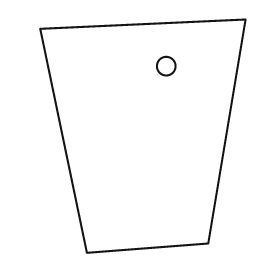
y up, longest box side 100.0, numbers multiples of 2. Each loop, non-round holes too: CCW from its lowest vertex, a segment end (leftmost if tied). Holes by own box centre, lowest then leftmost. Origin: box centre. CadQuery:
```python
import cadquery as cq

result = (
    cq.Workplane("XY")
    .moveTo(-24.0, -50.0)
    .lineTo(28.0, -46.0)
    .lineTo(44.0, 50.0)
    .lineTo(-44.0, 46.0)
    .close()
    .moveTo(10.0, 30.0)
    .circle(4.0)
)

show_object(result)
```